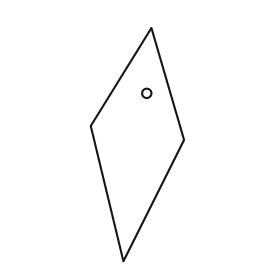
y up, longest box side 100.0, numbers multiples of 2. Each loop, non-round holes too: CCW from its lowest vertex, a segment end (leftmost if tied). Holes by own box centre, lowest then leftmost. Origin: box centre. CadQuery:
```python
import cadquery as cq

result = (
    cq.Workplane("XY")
    .moveTo(-6.0, -50.0)
    .lineTo(20.0, 2.0)
    .lineTo(6.0, 50.0)
    .lineTo(-20.0, 8.0)
    .close()
    .moveTo(4.0, 22.0)
    .circle(2.0)
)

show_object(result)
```